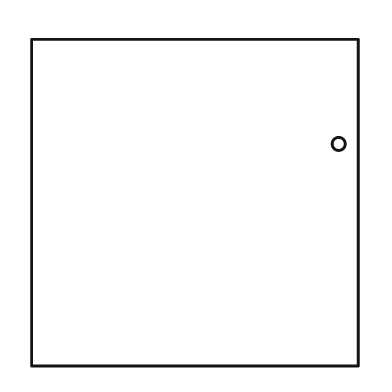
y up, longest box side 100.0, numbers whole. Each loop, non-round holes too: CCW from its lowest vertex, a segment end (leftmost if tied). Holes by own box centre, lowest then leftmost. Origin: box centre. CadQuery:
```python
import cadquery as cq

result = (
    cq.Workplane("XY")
    .moveTo(-50.0, -50.0)
    .lineTo(50.0, -50.0)
    .lineTo(50.0, 50.0)
    .lineTo(-50.0, 50.0)
    .close()
    .moveTo(44.0, 18.0)
    .circle(2.0)
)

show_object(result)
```